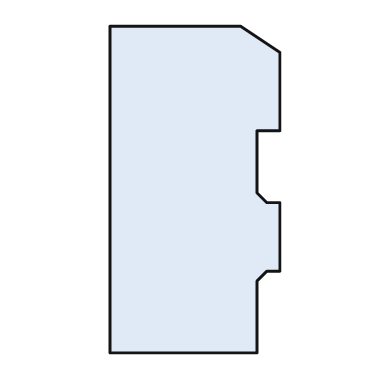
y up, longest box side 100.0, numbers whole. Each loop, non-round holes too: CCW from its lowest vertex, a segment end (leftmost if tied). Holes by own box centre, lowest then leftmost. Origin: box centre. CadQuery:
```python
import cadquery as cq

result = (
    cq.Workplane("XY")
    .moveTo(-26.0, -50.0)
    .lineTo(19.0, -50.0)
    .lineTo(19.0, -28.0)
    .lineTo(22.0, -25.0)
    .lineTo(26.0, -25.0)
    .lineTo(26.0, -4.0)
    .lineTo(22.0, -4.0)
    .lineTo(19.0, -1.0)
    .lineTo(19.0, 18.0)
    .lineTo(26.0, 18.0)
    .lineTo(26.0, 42.0)
    .lineTo(14.0, 50.0)
    .lineTo(-26.0, 50.0)
    .close()
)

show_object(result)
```